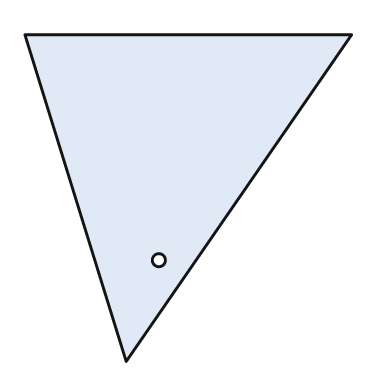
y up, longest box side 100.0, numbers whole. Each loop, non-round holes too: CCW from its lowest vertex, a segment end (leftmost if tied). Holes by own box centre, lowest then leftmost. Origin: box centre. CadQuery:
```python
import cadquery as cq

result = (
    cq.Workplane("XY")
    .moveTo(-19.0, -50.0)
    .lineTo(50.0, 50.0)
    .lineTo(-50.0, 50.0)
    .close()
    .moveTo(-9.0, -19.0)
    .circle(2.0)
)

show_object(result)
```